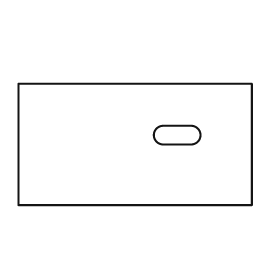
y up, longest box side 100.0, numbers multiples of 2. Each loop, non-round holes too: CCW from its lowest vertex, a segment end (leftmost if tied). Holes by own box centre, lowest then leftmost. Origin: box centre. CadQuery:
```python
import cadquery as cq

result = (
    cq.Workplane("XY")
    .moveTo(-50.0, -26.0)
    .lineTo(50.0, -26.0)
    .lineTo(50.0, 26.0)
    .lineTo(-50.0, 26.0)
    .close()
    .moveTo(12.0, 0.0)
    .lineTo(24.0, 0.0)
    .threePointArc((28.0, 4.0), (24.0, 8.0))
    .lineTo(12.0, 8.0)
    .threePointArc((8.0, 4.0), (12.0, 0.0))
    .close()
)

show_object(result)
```